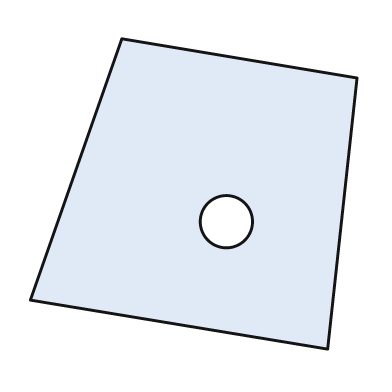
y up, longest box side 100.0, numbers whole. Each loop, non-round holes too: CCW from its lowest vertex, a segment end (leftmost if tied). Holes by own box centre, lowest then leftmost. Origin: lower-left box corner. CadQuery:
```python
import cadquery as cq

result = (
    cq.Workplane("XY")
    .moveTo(91.0, 0.0)
    .lineTo(100.0, 83.0)
    .lineTo(28.0, 95.0)
    .lineTo(0.0, 15.0)
    .close()
    .moveTo(60.0, 39.0)
    .circle(8.0)
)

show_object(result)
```